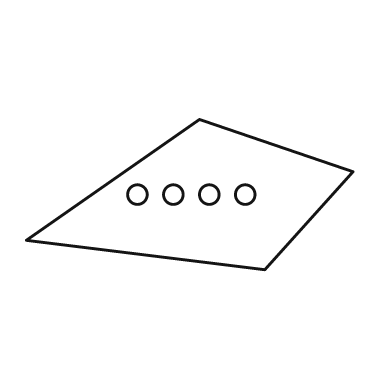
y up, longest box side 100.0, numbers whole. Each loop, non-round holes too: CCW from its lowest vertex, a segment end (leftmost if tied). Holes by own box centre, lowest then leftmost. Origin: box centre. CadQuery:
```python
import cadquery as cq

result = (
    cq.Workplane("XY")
    .moveTo(23.0, -23.0)
    .lineTo(50.0, 7.0)
    .lineTo(3.0, 23.0)
    .lineTo(-50.0, -14.0)
    .close()
    .moveTo(-16.0, 0.0)
    .circle(3.0)
    .moveTo(-5.0, 0.0)
    .circle(3.0)
    .moveTo(6.0, 0.0)
    .circle(3.0)
    .moveTo(17.0, 0.0)
    .circle(3.0)
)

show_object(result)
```